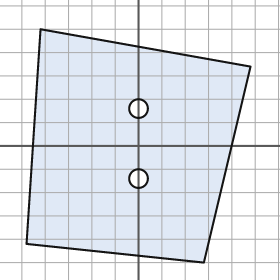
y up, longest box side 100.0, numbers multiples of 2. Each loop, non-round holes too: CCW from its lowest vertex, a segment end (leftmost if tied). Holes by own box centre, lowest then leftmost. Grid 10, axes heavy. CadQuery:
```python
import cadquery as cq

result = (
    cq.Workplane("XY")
    .moveTo(28.0, -50.0)
    .lineTo(48.0, 34.0)
    .lineTo(-42.0, 50.0)
    .lineTo(-48.0, -42.0)
    .close()
    .moveTo(0.0, -14.0)
    .circle(4.0)
    .moveTo(0.0, 16.0)
    .circle(4.0)
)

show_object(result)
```